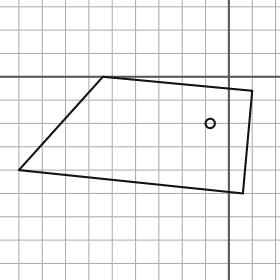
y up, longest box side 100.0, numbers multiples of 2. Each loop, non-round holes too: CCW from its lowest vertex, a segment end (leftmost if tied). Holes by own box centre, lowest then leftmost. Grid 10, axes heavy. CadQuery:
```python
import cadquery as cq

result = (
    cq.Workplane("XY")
    .moveTo(6.0, -50.0)
    .lineTo(10.0, -6.0)
    .lineTo(-54.0, 0.0)
    .lineTo(-90.0, -40.0)
    .close()
    .moveTo(-8.0, -20.0)
    .circle(2.0)
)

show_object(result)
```